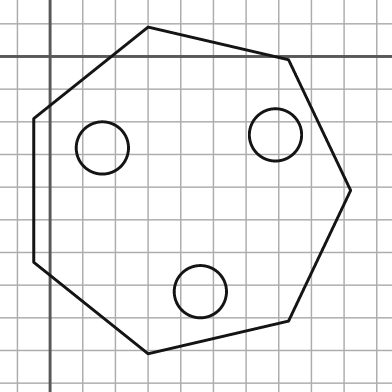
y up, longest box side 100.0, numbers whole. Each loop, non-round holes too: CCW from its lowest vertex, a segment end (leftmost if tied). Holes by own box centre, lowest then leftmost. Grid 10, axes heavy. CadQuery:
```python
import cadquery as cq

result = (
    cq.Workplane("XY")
    .moveTo(30.0, -91.0)
    .lineTo(73.0, -81.0)
    .lineTo(92.0, -41.0)
    .lineTo(73.0, -1.0)
    .lineTo(30.0, 9.0)
    .lineTo(-5.0, -19.0)
    .lineTo(-5.0, -63.0)
    .close()
    .moveTo(46.0, -72.0)
    .circle(8.0)
    .moveTo(16.0, -28.0)
    .circle(8.0)
    .moveTo(69.0, -24.0)
    .circle(8.0)
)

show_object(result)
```